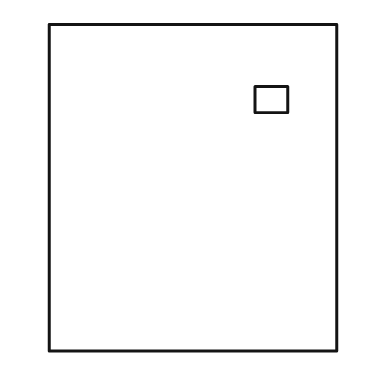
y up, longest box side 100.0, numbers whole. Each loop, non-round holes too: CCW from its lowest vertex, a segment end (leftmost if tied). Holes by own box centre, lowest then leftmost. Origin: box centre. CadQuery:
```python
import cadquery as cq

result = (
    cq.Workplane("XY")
    .moveTo(-44.0, -50.0)
    .lineTo(44.0, -50.0)
    .lineTo(44.0, 50.0)
    .lineTo(-44.0, 50.0)
    .close()
    .moveTo(19.0, 23.0)
    .lineTo(29.0, 23.0)
    .lineTo(29.0, 31.0)
    .lineTo(19.0, 31.0)
    .close()
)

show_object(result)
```